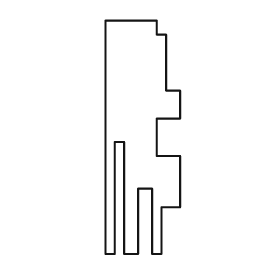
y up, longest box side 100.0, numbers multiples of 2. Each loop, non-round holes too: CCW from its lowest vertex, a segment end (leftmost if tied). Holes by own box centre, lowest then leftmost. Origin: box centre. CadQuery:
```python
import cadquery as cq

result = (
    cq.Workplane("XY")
    .moveTo(-16.0, -50.0)
    .lineTo(-12.0, -50.0)
    .lineTo(-12.0, -2.0)
    .lineTo(-8.0, -2.0)
    .lineTo(-8.0, -50.0)
    .lineTo(-2.0, -50.0)
    .lineTo(-2.0, -22.0)
    .lineTo(4.0, -22.0)
    .lineTo(4.0, -50.0)
    .lineTo(8.0, -50.0)
    .lineTo(8.0, -30.0)
    .lineTo(16.0, -30.0)
    .lineTo(16.0, -8.0)
    .lineTo(6.0, -8.0)
    .lineTo(6.0, 8.0)
    .lineTo(16.0, 8.0)
    .lineTo(16.0, 20.0)
    .lineTo(10.0, 20.0)
    .lineTo(10.0, 44.0)
    .lineTo(6.0, 44.0)
    .lineTo(6.0, 50.0)
    .lineTo(-16.0, 50.0)
    .close()
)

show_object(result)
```